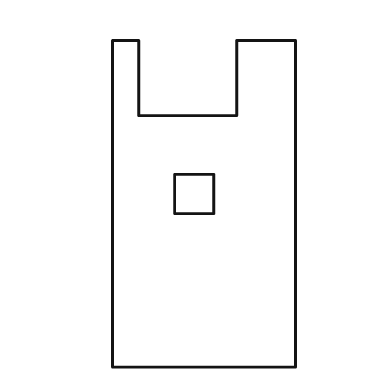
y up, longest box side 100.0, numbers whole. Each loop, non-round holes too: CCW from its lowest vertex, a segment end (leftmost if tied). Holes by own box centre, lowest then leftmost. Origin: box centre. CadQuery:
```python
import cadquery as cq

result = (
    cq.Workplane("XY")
    .moveTo(-28.0, -50.0)
    .lineTo(28.0, -50.0)
    .lineTo(28.0, 50.0)
    .lineTo(10.0, 50.0)
    .lineTo(10.0, 27.0)
    .lineTo(-20.0, 27.0)
    .lineTo(-20.0, 50.0)
    .lineTo(-28.0, 50.0)
    .close()
    .moveTo(-9.0, -3.0)
    .lineTo(3.0, -3.0)
    .lineTo(3.0, 9.0)
    .lineTo(-9.0, 9.0)
    .close()
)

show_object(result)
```